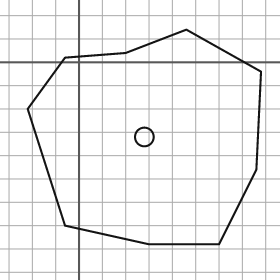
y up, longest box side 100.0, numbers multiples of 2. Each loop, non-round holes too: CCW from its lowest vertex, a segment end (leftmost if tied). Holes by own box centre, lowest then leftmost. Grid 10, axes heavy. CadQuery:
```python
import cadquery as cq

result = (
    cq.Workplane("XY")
    .moveTo(30.0, -78.0)
    .lineTo(60.0, -78.0)
    .lineTo(76.0, -46.0)
    .lineTo(78.0, -4.0)
    .lineTo(46.0, 14.0)
    .lineTo(20.0, 4.0)
    .lineTo(-6.0, 2.0)
    .lineTo(-22.0, -20.0)
    .lineTo(-6.0, -70.0)
    .close()
    .moveTo(28.0, -32.0)
    .circle(4.0)
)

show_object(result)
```